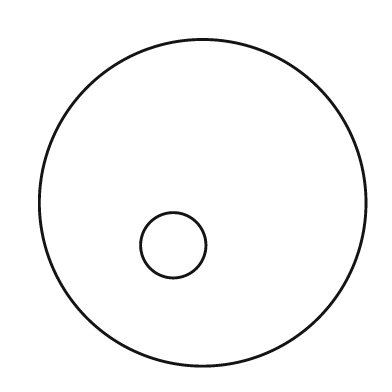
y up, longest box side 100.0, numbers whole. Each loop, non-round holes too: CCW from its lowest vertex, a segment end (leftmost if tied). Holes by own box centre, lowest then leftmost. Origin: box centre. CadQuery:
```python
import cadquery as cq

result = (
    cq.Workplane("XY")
    .moveTo(0.0, 0.0)
    .circle(50.0)
    .moveTo(-9.0, -13.0)
    .circle(10.0)
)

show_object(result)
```